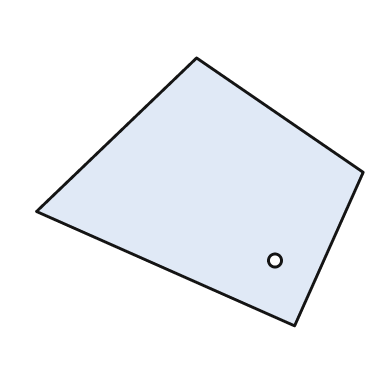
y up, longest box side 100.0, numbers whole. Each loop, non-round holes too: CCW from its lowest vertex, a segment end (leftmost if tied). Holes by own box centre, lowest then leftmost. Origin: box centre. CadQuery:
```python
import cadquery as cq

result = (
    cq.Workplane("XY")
    .moveTo(29.0, -41.0)
    .lineTo(50.0, 6.0)
    .lineTo(-1.0, 41.0)
    .lineTo(-50.0, -6.0)
    .close()
    .moveTo(23.0, -21.0)
    .circle(2.0)
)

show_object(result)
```